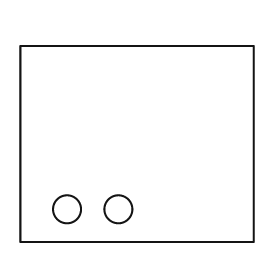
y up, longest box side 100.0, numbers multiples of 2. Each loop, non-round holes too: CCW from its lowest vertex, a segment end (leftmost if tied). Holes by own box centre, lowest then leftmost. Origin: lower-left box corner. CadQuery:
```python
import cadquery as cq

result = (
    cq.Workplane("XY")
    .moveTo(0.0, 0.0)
    .lineTo(100.0, 0.0)
    .lineTo(100.0, 84.0)
    .lineTo(0.0, 84.0)
    .close()
    .moveTo(20.0, 14.0)
    .circle(6.0)
    .moveTo(42.0, 14.0)
    .circle(6.0)
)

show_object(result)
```